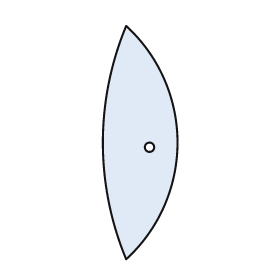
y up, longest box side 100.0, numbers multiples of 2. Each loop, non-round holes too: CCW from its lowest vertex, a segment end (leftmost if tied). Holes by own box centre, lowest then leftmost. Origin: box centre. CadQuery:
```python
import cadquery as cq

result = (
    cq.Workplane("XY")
    .moveTo(-6.0, -50.0)
    .threePointArc((16.0, 0.0), (-6.0, 50.0))
    .threePointArc((-16.0, 0.0), (-6.0, -50.0))
    .close()
    .moveTo(4.0, -2.0)
    .circle(2.0)
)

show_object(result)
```